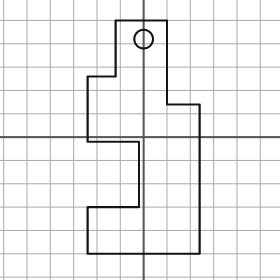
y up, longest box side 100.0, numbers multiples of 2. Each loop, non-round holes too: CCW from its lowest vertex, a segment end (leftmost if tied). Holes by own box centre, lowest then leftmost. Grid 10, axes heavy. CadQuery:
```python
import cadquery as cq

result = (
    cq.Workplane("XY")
    .moveTo(-24.0, -50.0)
    .lineTo(24.0, -50.0)
    .lineTo(24.0, 14.0)
    .lineTo(10.0, 14.0)
    .lineTo(10.0, 50.0)
    .lineTo(-12.0, 50.0)
    .lineTo(-12.0, 26.0)
    .lineTo(-24.0, 26.0)
    .lineTo(-24.0, -2.0)
    .lineTo(-2.0, -2.0)
    .lineTo(-2.0, -30.0)
    .lineTo(-24.0, -30.0)
    .close()
    .moveTo(0.0, 42.0)
    .circle(4.0)
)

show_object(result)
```